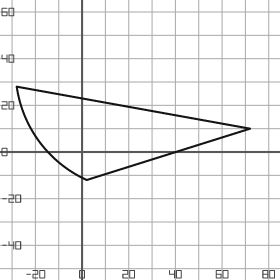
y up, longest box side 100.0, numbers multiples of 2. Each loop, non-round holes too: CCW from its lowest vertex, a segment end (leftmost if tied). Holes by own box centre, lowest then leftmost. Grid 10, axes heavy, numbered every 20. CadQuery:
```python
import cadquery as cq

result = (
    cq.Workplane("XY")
    .moveTo(2.0, -12.0)
    .lineTo(72.0, 10.0)
    .lineTo(-28.0, 28.0)
    .threePointArc((-18.0, 4.0), (2.0, -12.0))
    .close()
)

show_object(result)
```